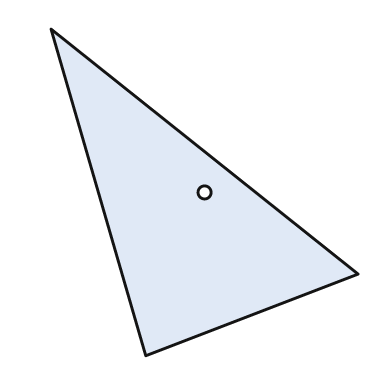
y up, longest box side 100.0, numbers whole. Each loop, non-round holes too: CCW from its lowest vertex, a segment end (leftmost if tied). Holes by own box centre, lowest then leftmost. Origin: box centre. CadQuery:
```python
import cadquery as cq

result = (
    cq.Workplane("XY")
    .moveTo(-18.0, -50.0)
    .lineTo(47.0, -25.0)
    .lineTo(-47.0, 50.0)
    .close()
    .moveTo(0.0, 0.0)
    .circle(2.0)
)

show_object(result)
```